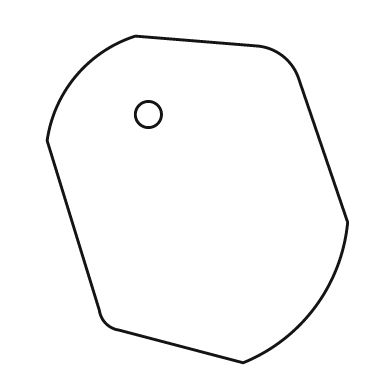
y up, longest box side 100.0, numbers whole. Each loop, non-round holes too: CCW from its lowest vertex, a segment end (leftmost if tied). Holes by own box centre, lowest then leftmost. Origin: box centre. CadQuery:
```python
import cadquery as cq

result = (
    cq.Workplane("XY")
    .moveTo(14.0, -50.0)
    .threePointArc((36.0, -33.0), (46.0, -7.0))
    .lineTo(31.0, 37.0)
    .threePointArc((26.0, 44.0), (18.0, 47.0))
    .lineTo(-19.0, 50.0)
    .threePointArc((-37.0, 38.0), (-46.0, 18.0))
    .lineTo(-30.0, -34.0)
    .threePointArc((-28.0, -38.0), (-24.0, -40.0))
    .close()
    .moveTo(-15.0, 26.0)
    .circle(4.0)
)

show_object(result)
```